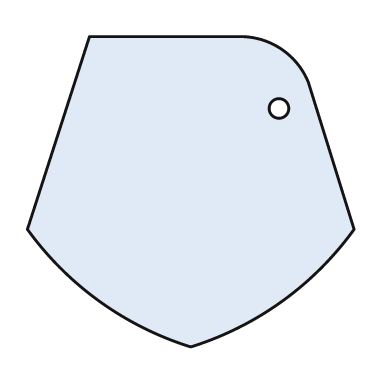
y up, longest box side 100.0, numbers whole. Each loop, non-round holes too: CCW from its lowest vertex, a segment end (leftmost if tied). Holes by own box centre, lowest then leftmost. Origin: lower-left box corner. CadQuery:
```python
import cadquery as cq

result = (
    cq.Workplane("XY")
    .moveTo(50.0, 0.0)
    .threePointArc((78.0, 14.0), (100.0, 36.0))
    .lineTo(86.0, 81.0)
    .threePointArc((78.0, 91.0), (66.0, 95.0))
    .lineTo(19.0, 95.0)
    .lineTo(0.0, 36.0)
    .threePointArc((22.0, 14.0), (50.0, 0.0))
    .close()
    .moveTo(77.0, 73.0)
    .circle(3.0)
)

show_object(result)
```